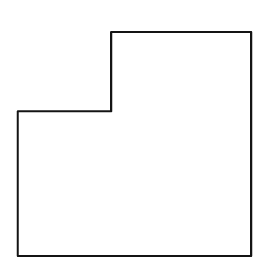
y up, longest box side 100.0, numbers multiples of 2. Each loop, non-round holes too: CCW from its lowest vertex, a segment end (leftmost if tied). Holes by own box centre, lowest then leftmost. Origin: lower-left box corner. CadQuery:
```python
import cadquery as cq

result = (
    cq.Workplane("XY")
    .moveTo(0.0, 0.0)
    .lineTo(100.0, 0.0)
    .lineTo(100.0, 96.0)
    .lineTo(40.0, 96.0)
    .lineTo(40.0, 62.0)
    .lineTo(0.0, 62.0)
    .close()
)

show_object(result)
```